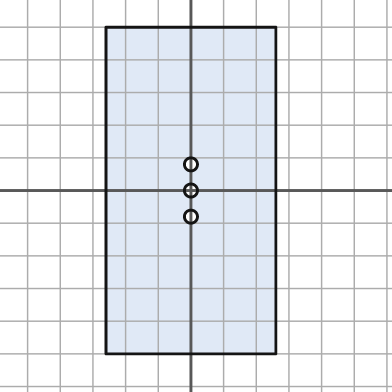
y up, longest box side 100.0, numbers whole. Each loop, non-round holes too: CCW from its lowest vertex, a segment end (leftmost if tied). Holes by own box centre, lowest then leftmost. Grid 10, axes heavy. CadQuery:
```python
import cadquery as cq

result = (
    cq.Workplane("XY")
    .moveTo(-26.0, -50.0)
    .lineTo(26.0, -50.0)
    .lineTo(26.0, 50.0)
    .lineTo(-26.0, 50.0)
    .close()
    .moveTo(0.0, -8.0)
    .circle(2.0)
    .moveTo(0.0, 0.0)
    .circle(2.0)
    .moveTo(0.0, 8.0)
    .circle(2.0)
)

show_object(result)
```